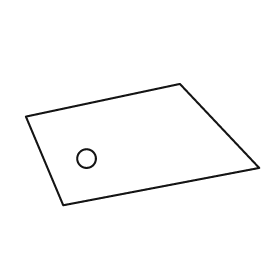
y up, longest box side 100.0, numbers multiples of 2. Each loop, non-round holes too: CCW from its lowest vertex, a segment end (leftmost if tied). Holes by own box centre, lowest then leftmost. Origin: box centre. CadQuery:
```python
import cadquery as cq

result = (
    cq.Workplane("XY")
    .moveTo(-34.0, -26.0)
    .lineTo(50.0, -10.0)
    .lineTo(16.0, 26.0)
    .lineTo(-50.0, 12.0)
    .close()
    .moveTo(-24.0, -6.0)
    .circle(4.0)
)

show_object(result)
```